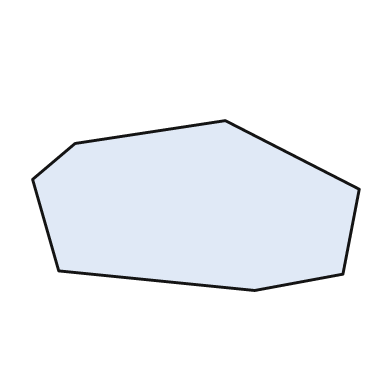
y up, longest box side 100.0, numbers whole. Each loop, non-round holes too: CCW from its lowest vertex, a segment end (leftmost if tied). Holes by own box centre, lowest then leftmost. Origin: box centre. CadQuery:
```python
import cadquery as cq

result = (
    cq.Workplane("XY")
    .moveTo(18.0, -26.0)
    .lineTo(45.0, -21.0)
    .lineTo(50.0, 5.0)
    .lineTo(9.0, 26.0)
    .lineTo(-37.0, 19.0)
    .lineTo(-50.0, 8.0)
    .lineTo(-42.0, -20.0)
    .close()
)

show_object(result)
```